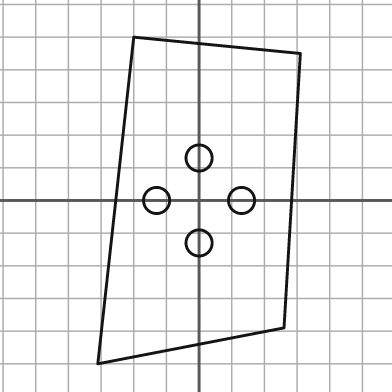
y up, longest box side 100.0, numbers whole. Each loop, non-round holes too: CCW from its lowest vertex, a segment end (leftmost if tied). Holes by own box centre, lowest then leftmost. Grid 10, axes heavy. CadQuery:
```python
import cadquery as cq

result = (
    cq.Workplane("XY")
    .moveTo(-31.0, -50.0)
    .lineTo(26.0, -39.0)
    .lineTo(31.0, 45.0)
    .lineTo(-20.0, 50.0)
    .close()
    .moveTo(0.0, -13.0)
    .circle(4.0)
    .moveTo(-13.0, 0.0)
    .circle(4.0)
    .moveTo(13.0, 0.0)
    .circle(4.0)
    .moveTo(0.0, 13.0)
    .circle(4.0)
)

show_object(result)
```